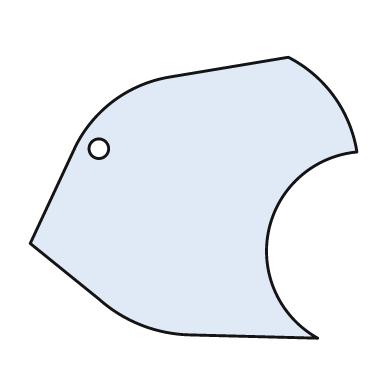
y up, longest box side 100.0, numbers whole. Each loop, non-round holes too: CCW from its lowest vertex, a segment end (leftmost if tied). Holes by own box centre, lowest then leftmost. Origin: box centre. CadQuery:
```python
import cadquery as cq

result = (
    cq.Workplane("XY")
    .moveTo(38.0, -43.0)
    .threePointArc((23.0, -10.0), (50.0, 14.0))
    .threePointArc((43.0, 31.0), (29.0, 43.0))
    .lineTo(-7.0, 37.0)
    .threePointArc((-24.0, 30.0), (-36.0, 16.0))
    .lineTo(-50.0, -14.0)
    .lineTo(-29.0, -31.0)
    .threePointArc((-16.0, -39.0), (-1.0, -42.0))
    .close()
    .moveTo(-29.0, 15.0)
    .circle(3.0)
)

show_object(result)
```